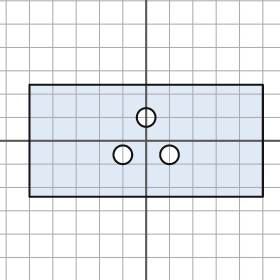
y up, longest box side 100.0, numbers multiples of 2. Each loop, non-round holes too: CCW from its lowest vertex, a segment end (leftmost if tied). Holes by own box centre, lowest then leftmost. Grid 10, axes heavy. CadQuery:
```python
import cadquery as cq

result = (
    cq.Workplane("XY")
    .moveTo(-50.0, -24.0)
    .lineTo(50.0, -24.0)
    .lineTo(50.0, 24.0)
    .lineTo(-50.0, 24.0)
    .close()
    .moveTo(-10.0, -6.0)
    .circle(4.0)
    .moveTo(10.0, -6.0)
    .circle(4.0)
    .moveTo(0.0, 10.0)
    .circle(4.0)
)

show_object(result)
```